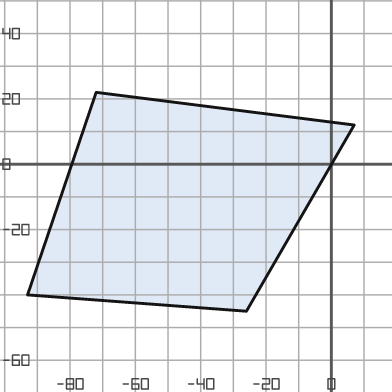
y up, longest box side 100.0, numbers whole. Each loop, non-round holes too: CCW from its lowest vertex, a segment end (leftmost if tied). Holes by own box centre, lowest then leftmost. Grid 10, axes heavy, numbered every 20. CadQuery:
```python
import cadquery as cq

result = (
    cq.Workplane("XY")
    .moveTo(-26.0, -45.0)
    .lineTo(7.0, 12.0)
    .lineTo(-72.0, 22.0)
    .lineTo(-93.0, -40.0)
    .close()
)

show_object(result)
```